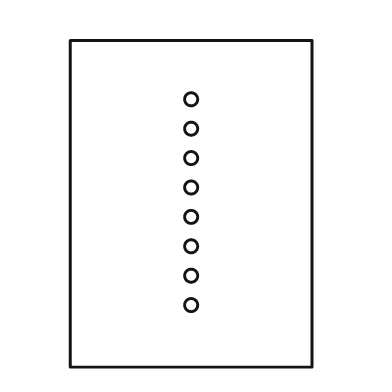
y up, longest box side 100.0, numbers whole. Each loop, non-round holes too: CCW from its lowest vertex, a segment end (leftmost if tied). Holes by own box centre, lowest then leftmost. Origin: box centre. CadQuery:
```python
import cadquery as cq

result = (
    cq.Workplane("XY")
    .moveTo(-37.0, -50.0)
    .lineTo(37.0, -50.0)
    .lineTo(37.0, 50.0)
    .lineTo(-37.0, 50.0)
    .close()
    .moveTo(0.0, -31.0)
    .circle(2.0)
    .moveTo(0.0, -22.0)
    .circle(2.0)
    .moveTo(0.0, -13.0)
    .circle(2.0)
    .moveTo(0.0, -4.0)
    .circle(2.0)
    .moveTo(0.0, 5.0)
    .circle(2.0)
    .moveTo(0.0, 14.0)
    .circle(2.0)
    .moveTo(0.0, 23.0)
    .circle(2.0)
    .moveTo(0.0, 32.0)
    .circle(2.0)
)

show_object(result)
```